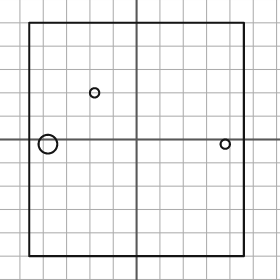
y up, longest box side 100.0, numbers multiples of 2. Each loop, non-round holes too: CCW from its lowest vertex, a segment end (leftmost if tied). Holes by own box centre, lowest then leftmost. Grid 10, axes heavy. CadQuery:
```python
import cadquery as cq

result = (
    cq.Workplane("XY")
    .moveTo(-46.0, -50.0)
    .lineTo(46.0, -50.0)
    .lineTo(46.0, 50.0)
    .lineTo(-46.0, 50.0)
    .close()
    .moveTo(-38.0, -2.0)
    .circle(4.0)
    .moveTo(38.0, -2.0)
    .circle(2.0)
    .moveTo(-18.0, 20.0)
    .circle(2.0)
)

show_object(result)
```